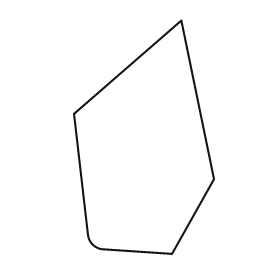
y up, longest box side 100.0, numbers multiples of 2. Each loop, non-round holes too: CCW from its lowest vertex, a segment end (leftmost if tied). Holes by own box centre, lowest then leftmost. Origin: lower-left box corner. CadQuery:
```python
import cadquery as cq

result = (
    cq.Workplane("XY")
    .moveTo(42.0, 0.0)
    .lineTo(60.0, 32.0)
    .lineTo(46.0, 100.0)
    .lineTo(0.0, 60.0)
    .lineTo(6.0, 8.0)
    .threePointArc((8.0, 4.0), (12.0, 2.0))
    .close()
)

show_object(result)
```